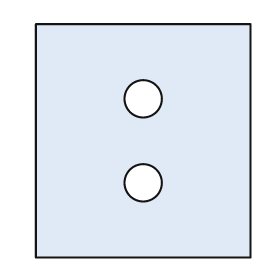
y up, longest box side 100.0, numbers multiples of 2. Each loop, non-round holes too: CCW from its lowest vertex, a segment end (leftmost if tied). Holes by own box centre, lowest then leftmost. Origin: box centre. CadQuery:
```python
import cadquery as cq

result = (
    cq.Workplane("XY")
    .moveTo(-46.0, -50.0)
    .lineTo(46.0, -50.0)
    .lineTo(46.0, 50.0)
    .lineTo(-46.0, 50.0)
    .close()
    .moveTo(0.0, -18.0)
    .circle(8.0)
    .moveTo(0.0, 18.0)
    .circle(8.0)
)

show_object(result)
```